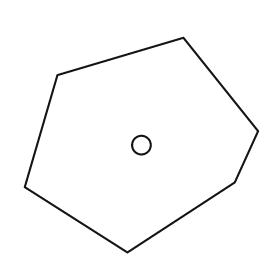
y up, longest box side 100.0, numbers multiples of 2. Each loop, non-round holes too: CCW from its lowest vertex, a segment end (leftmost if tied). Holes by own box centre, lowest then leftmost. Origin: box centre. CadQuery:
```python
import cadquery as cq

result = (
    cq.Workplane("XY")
    .moveTo(-6.0, -46.0)
    .lineTo(40.0, -16.0)
    .lineTo(50.0, 6.0)
    .lineTo(18.0, 46.0)
    .lineTo(-36.0, 30.0)
    .lineTo(-50.0, -18.0)
    .close()
    .moveTo(0.0, 0.0)
    .circle(4.0)
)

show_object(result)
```